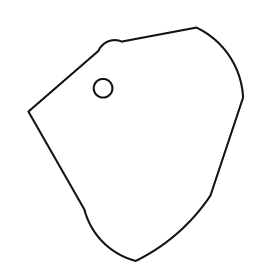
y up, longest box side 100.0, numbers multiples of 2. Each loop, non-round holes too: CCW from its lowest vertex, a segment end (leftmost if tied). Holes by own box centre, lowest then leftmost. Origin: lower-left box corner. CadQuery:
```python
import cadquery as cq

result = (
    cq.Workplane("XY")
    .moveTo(46.0, 0.0)
    .threePointArc((64.0, 12.0), (78.0, 28.0))
    .lineTo(92.0, 70.0)
    .threePointArc((86.0, 88.0), (72.0, 100.0))
    .lineTo(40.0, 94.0)
    .threePointArc((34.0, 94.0), (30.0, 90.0))
    .lineTo(0.0, 64.0)
    .lineTo(24.0, 22.0)
    .threePointArc((32.0, 8.0), (46.0, 0.0))
    .close()
    .moveTo(32.0, 74.0)
    .circle(4.0)
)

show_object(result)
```